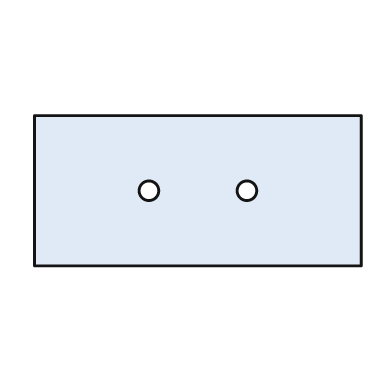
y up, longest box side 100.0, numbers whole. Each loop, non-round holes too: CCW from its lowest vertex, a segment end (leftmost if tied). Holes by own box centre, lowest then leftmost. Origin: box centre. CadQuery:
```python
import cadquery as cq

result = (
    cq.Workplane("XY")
    .moveTo(-50.0, -23.0)
    .lineTo(50.0, -23.0)
    .lineTo(50.0, 23.0)
    .lineTo(-50.0, 23.0)
    .close()
    .moveTo(-15.0, 0.0)
    .circle(3.0)
    .moveTo(15.0, 0.0)
    .circle(3.0)
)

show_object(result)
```